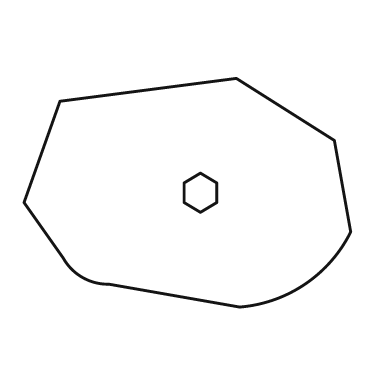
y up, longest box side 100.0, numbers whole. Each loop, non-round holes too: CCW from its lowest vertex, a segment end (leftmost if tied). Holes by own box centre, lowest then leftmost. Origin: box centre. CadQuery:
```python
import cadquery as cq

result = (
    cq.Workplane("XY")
    .moveTo(16.0, -35.0)
    .threePointArc((36.0, -28.0), (50.0, -12.0))
    .lineTo(45.0, 16.0)
    .lineTo(15.0, 35.0)
    .lineTo(-39.0, 28.0)
    .lineTo(-50.0, -3.0)
    .lineTo(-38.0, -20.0)
    .threePointArc((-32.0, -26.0), (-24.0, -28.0))
    .close()
    .moveTo(4.0, -6.0)
    .lineTo(9.0, -3.0)
    .lineTo(9.0, 3.0)
    .lineTo(4.0, 6.0)
    .lineTo(-1.0, 3.0)
    .lineTo(-1.0, -3.0)
    .close()
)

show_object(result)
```